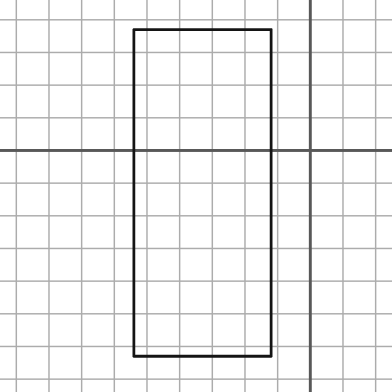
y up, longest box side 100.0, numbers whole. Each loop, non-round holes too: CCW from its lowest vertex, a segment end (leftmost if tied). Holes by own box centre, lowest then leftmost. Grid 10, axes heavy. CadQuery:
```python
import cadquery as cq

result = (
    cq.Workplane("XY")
    .moveTo(-54.0, -63.0)
    .lineTo(-12.0, -63.0)
    .lineTo(-12.0, 37.0)
    .lineTo(-54.0, 37.0)
    .close()
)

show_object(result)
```